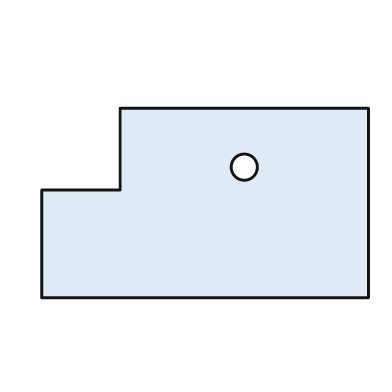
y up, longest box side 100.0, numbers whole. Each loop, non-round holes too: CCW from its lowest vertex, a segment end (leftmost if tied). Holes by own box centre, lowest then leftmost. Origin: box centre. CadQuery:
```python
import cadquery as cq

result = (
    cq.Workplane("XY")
    .moveTo(-50.0, -29.0)
    .lineTo(50.0, -29.0)
    .lineTo(50.0, 29.0)
    .lineTo(-26.0, 29.0)
    .lineTo(-26.0, 4.0)
    .lineTo(-50.0, 4.0)
    .close()
    .moveTo(12.0, 11.0)
    .circle(4.0)
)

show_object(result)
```